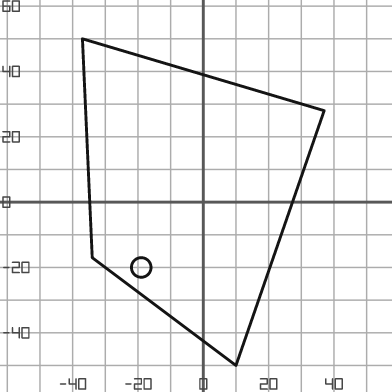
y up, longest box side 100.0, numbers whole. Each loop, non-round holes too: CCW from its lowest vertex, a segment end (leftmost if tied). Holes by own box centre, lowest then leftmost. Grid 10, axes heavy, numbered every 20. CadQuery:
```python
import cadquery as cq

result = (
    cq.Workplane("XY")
    .moveTo(10.0, -50.0)
    .lineTo(37.0, 28.0)
    .lineTo(-37.0, 50.0)
    .lineTo(-34.0, -17.0)
    .close()
    .moveTo(-19.0, -20.0)
    .circle(3.0)
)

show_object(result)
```